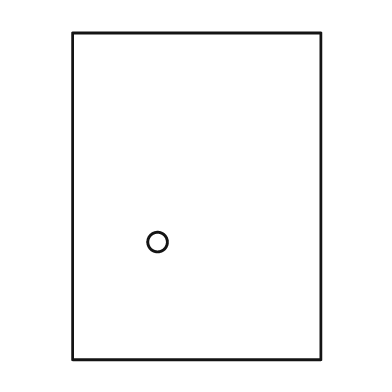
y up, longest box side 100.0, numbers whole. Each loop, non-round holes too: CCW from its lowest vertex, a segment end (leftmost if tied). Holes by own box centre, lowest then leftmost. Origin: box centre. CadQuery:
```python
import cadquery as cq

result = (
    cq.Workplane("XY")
    .moveTo(-38.0, -50.0)
    .lineTo(38.0, -50.0)
    .lineTo(38.0, 50.0)
    .lineTo(-38.0, 50.0)
    .close()
    .moveTo(-12.0, -14.0)
    .circle(3.0)
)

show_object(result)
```